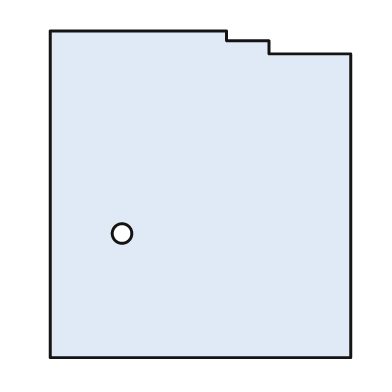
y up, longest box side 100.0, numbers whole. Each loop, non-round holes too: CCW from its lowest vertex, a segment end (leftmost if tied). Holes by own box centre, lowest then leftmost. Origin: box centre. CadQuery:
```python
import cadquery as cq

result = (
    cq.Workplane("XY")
    .moveTo(-46.0, -50.0)
    .lineTo(46.0, -50.0)
    .lineTo(46.0, 43.0)
    .lineTo(21.0, 43.0)
    .lineTo(21.0, 47.0)
    .lineTo(8.0, 47.0)
    .lineTo(8.0, 50.0)
    .lineTo(-46.0, 50.0)
    .close()
    .moveTo(-24.0, -12.0)
    .circle(3.0)
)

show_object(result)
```